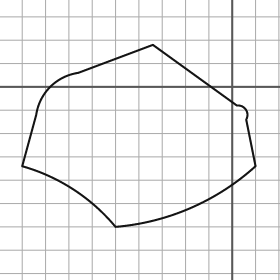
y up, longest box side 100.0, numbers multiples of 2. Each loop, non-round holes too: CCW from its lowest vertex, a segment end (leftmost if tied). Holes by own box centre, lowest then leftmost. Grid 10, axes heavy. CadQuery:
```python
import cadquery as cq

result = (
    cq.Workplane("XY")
    .moveTo(-50.0, -60.0)
    .threePointArc((-18.0, -52.0), (10.0, -34.0))
    .lineTo(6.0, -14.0)
    .threePointArc((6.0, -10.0), (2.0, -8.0))
    .lineTo(-34.0, 18.0)
    .lineTo(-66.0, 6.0)
    .threePointArc((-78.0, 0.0), (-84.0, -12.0))
    .lineTo(-90.0, -34.0)
    .threePointArc((-68.0, -44.0), (-50.0, -60.0))
    .close()
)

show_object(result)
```